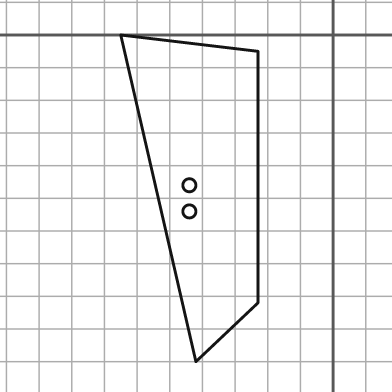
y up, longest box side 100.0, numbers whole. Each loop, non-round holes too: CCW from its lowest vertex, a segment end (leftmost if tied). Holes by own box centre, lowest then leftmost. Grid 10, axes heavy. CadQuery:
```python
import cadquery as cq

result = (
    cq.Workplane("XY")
    .moveTo(-42.0, -100.0)
    .lineTo(-23.0, -82.0)
    .lineTo(-23.0, -5.0)
    .lineTo(-65.0, 0.0)
    .close()
    .moveTo(-44.0, -54.0)
    .circle(2.0)
    .moveTo(-44.0, -46.0)
    .circle(2.0)
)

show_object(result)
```